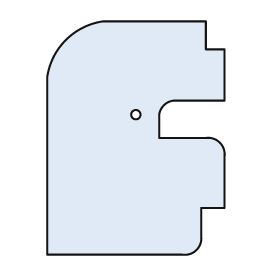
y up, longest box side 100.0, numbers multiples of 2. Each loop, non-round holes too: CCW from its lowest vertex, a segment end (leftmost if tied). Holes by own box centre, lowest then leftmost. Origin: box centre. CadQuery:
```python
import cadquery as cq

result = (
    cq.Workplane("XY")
    .moveTo(-38.0, -50.0)
    .lineTo(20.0, -50.0)
    .threePointArc((26.0, -48.0), (28.0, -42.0))
    .lineTo(28.0, -30.0)
    .lineTo(38.0, -30.0)
    .lineTo(38.0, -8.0)
    .threePointArc((36.0, -2.0), (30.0, 0.0))
    .lineTo(10.0, 0.0)
    .lineTo(10.0, 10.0)
    .threePointArc((12.0, 14.0), (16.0, 16.0))
    .lineTo(38.0, 16.0)
    .lineTo(38.0, 38.0)
    .lineTo(30.0, 38.0)
    .lineTo(30.0, 50.0)
    .lineTo(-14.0, 50.0)
    .threePointArc((-30.0, 42.0), (-38.0, 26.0))
    .close()
    .moveTo(0.0, 10.0)
    .circle(2.0)
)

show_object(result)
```